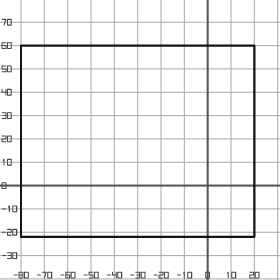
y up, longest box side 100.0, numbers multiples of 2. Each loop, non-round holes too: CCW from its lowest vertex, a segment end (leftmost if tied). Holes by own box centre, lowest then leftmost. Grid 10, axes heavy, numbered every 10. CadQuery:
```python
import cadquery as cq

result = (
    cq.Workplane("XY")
    .moveTo(-80.0, -22.0)
    .lineTo(20.0, -22.0)
    .lineTo(20.0, 60.0)
    .lineTo(-80.0, 60.0)
    .close()
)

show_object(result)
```